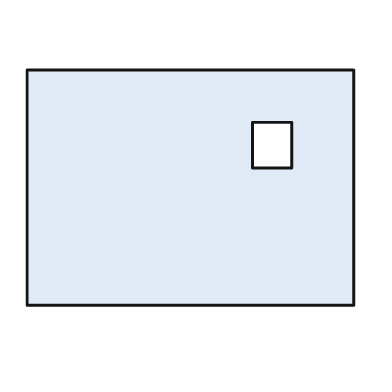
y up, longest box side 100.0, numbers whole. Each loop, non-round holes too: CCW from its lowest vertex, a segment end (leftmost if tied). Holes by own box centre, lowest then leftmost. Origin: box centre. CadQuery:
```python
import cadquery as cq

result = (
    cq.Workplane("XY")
    .moveTo(-50.0, -36.0)
    .lineTo(50.0, -36.0)
    .lineTo(50.0, 36.0)
    .lineTo(-50.0, 36.0)
    .close()
    .moveTo(19.0, 6.0)
    .lineTo(31.0, 6.0)
    .lineTo(31.0, 20.0)
    .lineTo(19.0, 20.0)
    .close()
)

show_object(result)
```